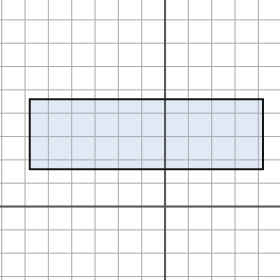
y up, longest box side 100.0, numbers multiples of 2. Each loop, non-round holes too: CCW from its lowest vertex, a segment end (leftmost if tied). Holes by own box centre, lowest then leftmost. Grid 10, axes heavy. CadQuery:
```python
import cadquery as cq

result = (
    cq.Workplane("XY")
    .moveTo(-58.0, 16.0)
    .lineTo(42.0, 16.0)
    .lineTo(42.0, 46.0)
    .lineTo(-58.0, 46.0)
    .close()
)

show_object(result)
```